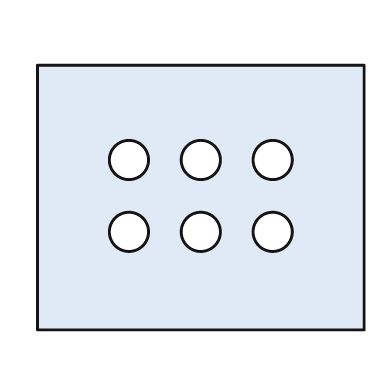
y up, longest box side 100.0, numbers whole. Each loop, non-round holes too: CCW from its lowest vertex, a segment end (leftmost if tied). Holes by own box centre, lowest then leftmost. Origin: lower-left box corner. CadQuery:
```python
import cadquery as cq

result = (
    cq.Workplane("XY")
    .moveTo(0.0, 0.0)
    .lineTo(100.0, 0.0)
    .lineTo(100.0, 81.0)
    .lineTo(0.0, 81.0)
    .close()
    .moveTo(28.0, 30.0)
    .circle(6.0)
    .moveTo(50.0, 30.0)
    .circle(6.0)
    .moveTo(72.0, 30.0)
    .circle(6.0)
    .moveTo(28.0, 52.0)
    .circle(6.0)
    .moveTo(50.0, 52.0)
    .circle(6.0)
    .moveTo(72.0, 52.0)
    .circle(6.0)
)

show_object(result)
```